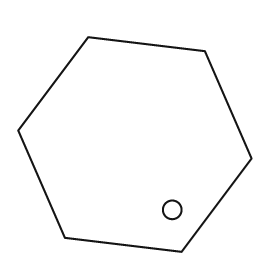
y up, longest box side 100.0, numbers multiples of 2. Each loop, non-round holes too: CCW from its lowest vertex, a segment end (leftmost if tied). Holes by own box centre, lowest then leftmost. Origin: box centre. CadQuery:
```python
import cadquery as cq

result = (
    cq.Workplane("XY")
    .moveTo(20.0, -46.0)
    .lineTo(50.0, -6.0)
    .lineTo(30.0, 40.0)
    .lineTo(-20.0, 46.0)
    .lineTo(-50.0, 6.0)
    .lineTo(-30.0, -40.0)
    .close()
    .moveTo(16.0, -28.0)
    .circle(4.0)
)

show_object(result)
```